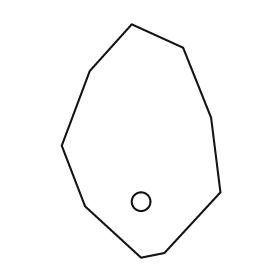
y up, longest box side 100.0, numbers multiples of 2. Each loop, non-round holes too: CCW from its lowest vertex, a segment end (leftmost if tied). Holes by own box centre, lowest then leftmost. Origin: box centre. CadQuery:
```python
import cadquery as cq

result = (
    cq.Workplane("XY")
    .moveTo(0.0, -50.0)
    .lineTo(10.0, -48.0)
    .lineTo(34.0, -22.0)
    .lineTo(30.0, 10.0)
    .lineTo(18.0, 40.0)
    .lineTo(-4.0, 50.0)
    .lineTo(-22.0, 30.0)
    .lineTo(-34.0, -2.0)
    .lineTo(-24.0, -28.0)
    .close()
    .moveTo(0.0, -26.0)
    .circle(4.0)
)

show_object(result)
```